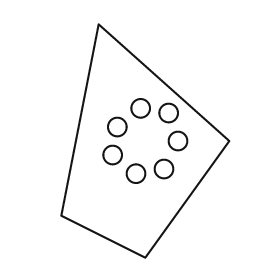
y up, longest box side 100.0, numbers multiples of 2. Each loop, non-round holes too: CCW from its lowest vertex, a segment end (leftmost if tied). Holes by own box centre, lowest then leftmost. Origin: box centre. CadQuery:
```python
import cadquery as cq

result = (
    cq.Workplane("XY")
    .moveTo(0.0, -50.0)
    .lineTo(36.0, 0.0)
    .lineTo(-20.0, 50.0)
    .lineTo(-36.0, -32.0)
    .close()
    .moveTo(-4.0, -14.0)
    .circle(4.0)
    .moveTo(8.0, -12.0)
    .circle(4.0)
    .moveTo(-14.0, -6.0)
    .circle(4.0)
    .moveTo(14.0, 0.0)
    .circle(4.0)
    .moveTo(-12.0, 6.0)
    .circle(4.0)
    .moveTo(10.0, 12.0)
    .circle(4.0)
    .moveTo(-2.0, 14.0)
    .circle(4.0)
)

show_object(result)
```